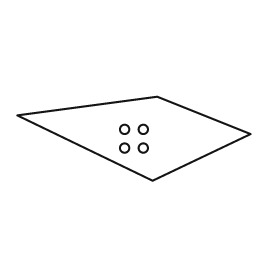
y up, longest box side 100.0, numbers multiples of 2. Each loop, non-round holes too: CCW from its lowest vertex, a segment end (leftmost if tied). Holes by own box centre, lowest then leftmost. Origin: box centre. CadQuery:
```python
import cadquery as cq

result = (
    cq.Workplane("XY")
    .moveTo(8.0, -18.0)
    .lineTo(50.0, 2.0)
    .lineTo(10.0, 18.0)
    .lineTo(-50.0, 10.0)
    .close()
    .moveTo(-4.0, -4.0)
    .circle(2.0)
    .moveTo(4.0, -4.0)
    .circle(2.0)
    .moveTo(-4.0, 4.0)
    .circle(2.0)
    .moveTo(4.0, 4.0)
    .circle(2.0)
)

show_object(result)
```